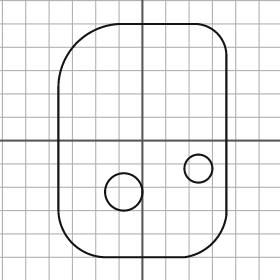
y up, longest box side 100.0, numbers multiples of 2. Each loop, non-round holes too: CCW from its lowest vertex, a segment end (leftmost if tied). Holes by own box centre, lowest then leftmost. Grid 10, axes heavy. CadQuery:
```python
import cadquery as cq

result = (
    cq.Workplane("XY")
    .moveTo(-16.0, -50.0)
    .lineTo(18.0, -50.0)
    .threePointArc((30.0, -44.0), (36.0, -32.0))
    .lineTo(36.0, 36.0)
    .threePointArc((32.0, 46.0), (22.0, 50.0))
    .lineTo(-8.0, 50.0)
    .threePointArc((-28.0, 42.0), (-36.0, 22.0))
    .lineTo(-36.0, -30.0)
    .threePointArc((-30.0, -44.0), (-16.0, -50.0))
    .close()
    .moveTo(-8.0, -22.0)
    .circle(8.0)
    .moveTo(24.0, -12.0)
    .circle(6.0)
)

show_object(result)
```